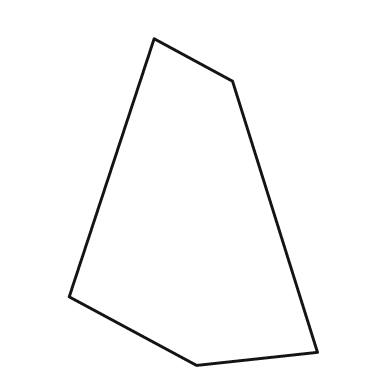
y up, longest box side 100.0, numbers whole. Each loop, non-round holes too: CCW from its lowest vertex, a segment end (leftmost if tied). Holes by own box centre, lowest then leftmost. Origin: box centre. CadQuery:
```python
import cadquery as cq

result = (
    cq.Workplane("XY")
    .moveTo(1.0, -50.0)
    .lineTo(38.0, -46.0)
    .lineTo(12.0, 37.0)
    .lineTo(-12.0, 50.0)
    .lineTo(-38.0, -29.0)
    .close()
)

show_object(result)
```